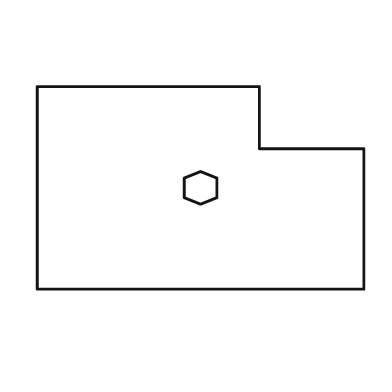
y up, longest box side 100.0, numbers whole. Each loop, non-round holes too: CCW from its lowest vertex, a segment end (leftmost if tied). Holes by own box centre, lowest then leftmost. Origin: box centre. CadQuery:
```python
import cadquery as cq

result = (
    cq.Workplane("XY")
    .moveTo(-50.0, -31.0)
    .lineTo(50.0, -31.0)
    .lineTo(50.0, 12.0)
    .lineTo(18.0, 12.0)
    .lineTo(18.0, 31.0)
    .lineTo(-50.0, 31.0)
    .close()
    .moveTo(0.0, -5.0)
    .lineTo(5.0, -3.0)
    .lineTo(5.0, 3.0)
    .lineTo(0.0, 5.0)
    .lineTo(-5.0, 3.0)
    .lineTo(-5.0, -3.0)
    .close()
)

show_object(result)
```